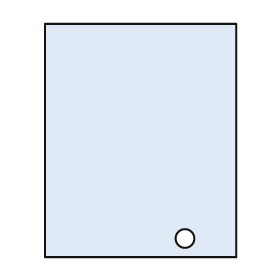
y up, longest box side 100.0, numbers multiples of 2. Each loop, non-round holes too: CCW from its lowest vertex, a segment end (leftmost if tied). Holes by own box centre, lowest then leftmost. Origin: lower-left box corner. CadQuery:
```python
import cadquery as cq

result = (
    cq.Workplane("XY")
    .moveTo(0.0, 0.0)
    .lineTo(82.0, 0.0)
    .lineTo(82.0, 100.0)
    .lineTo(0.0, 100.0)
    .close()
    .moveTo(60.0, 8.0)
    .circle(4.0)
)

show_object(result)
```